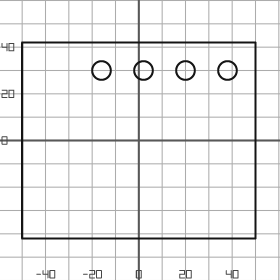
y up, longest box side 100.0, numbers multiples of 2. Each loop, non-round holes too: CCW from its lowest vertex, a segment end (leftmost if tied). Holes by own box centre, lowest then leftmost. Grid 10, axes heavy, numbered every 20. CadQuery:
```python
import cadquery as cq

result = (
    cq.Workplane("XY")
    .moveTo(-50.0, -42.0)
    .lineTo(50.0, -42.0)
    .lineTo(50.0, 42.0)
    .lineTo(-50.0, 42.0)
    .close()
    .moveTo(-16.0, 30.0)
    .circle(4.0)
    .moveTo(2.0, 30.0)
    .circle(4.0)
    .moveTo(20.0, 30.0)
    .circle(4.0)
    .moveTo(38.0, 30.0)
    .circle(4.0)
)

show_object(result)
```